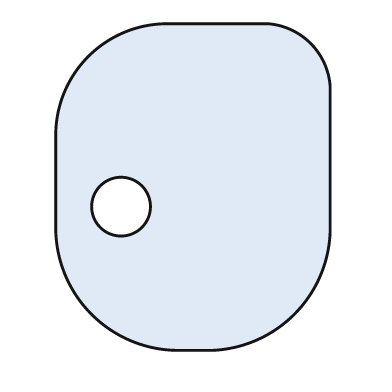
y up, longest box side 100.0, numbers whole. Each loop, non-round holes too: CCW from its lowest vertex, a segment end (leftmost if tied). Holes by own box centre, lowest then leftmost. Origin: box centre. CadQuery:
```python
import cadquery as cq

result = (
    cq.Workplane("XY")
    .moveTo(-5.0, -50.0)
    .lineTo(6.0, -50.0)
    .threePointArc((31.0, -39.0), (42.0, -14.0))
    .lineTo(42.0, 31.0)
    .threePointArc((36.0, 44.0), (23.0, 50.0))
    .lineTo(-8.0, 50.0)
    .threePointArc((-32.0, 40.0), (-42.0, 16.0))
    .lineTo(-42.0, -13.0)
    .threePointArc((-31.0, -39.0), (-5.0, -50.0))
    .close()
    .moveTo(-22.0, -6.0)
    .circle(9.0)
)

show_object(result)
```